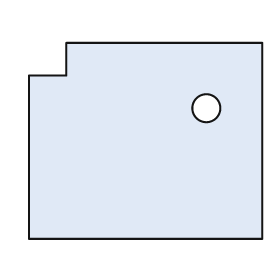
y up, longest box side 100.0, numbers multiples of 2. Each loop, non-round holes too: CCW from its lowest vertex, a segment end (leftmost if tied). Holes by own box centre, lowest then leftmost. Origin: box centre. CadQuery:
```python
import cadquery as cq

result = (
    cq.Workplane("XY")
    .moveTo(-50.0, -42.0)
    .lineTo(50.0, -42.0)
    .lineTo(50.0, 42.0)
    .lineTo(-34.0, 42.0)
    .lineTo(-34.0, 28.0)
    .lineTo(-50.0, 28.0)
    .close()
    .moveTo(26.0, 14.0)
    .circle(6.0)
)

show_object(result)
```